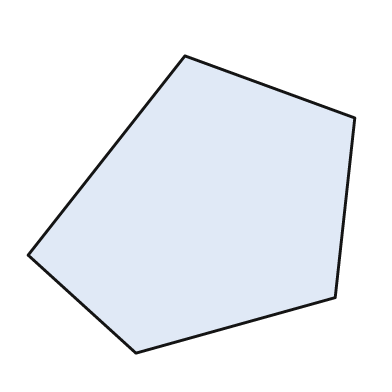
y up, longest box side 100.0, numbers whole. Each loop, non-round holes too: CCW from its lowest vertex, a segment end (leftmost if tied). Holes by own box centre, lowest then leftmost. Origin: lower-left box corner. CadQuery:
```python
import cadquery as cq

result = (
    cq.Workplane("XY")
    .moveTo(33.0, 0.0)
    .lineTo(94.0, 17.0)
    .lineTo(100.0, 72.0)
    .lineTo(48.0, 91.0)
    .lineTo(0.0, 30.0)
    .close()
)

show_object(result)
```